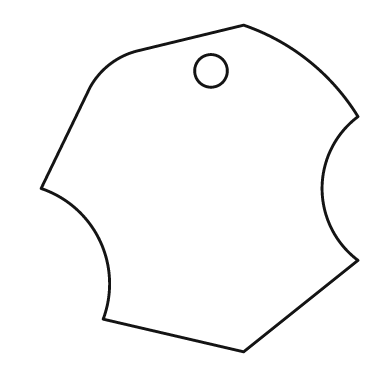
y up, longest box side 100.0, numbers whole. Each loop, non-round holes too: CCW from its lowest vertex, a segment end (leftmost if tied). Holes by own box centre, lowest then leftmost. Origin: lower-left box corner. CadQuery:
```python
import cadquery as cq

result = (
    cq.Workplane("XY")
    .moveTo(62.0, 0.0)
    .lineTo(97.0, 28.0)
    .threePointArc((86.0, 50.0), (97.0, 72.0))
    .threePointArc((82.0, 89.0), (62.0, 100.0))
    .lineTo(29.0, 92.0)
    .threePointArc((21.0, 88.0), (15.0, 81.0))
    .lineTo(0.0, 50.0)
    .threePointArc((18.0, 34.0), (19.0, 10.0))
    .close()
    .moveTo(52.0, 86.0)
    .circle(5.0)
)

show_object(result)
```